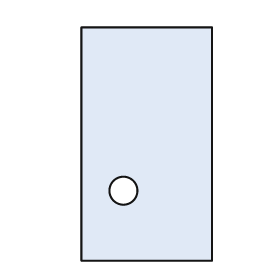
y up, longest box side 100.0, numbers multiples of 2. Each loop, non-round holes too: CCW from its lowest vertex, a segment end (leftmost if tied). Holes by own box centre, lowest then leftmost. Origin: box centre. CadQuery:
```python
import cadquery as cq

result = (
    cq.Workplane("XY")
    .moveTo(-28.0, -50.0)
    .lineTo(28.0, -50.0)
    .lineTo(28.0, 50.0)
    .lineTo(-28.0, 50.0)
    .close()
    .moveTo(-10.0, -20.0)
    .circle(6.0)
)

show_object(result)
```